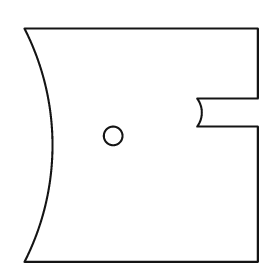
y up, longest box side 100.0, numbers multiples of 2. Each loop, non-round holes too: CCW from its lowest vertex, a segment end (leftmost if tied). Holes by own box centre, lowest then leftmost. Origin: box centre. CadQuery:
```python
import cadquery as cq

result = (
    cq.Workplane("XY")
    .moveTo(-50.0, -50.0)
    .lineTo(50.0, -50.0)
    .lineTo(50.0, 8.0)
    .lineTo(24.0, 8.0)
    .threePointArc((26.0, 14.0), (24.0, 20.0))
    .lineTo(50.0, 20.0)
    .lineTo(50.0, 50.0)
    .lineTo(-50.0, 50.0)
    .threePointArc((-38.0, 0.0), (-50.0, -50.0))
    .close()
    .moveTo(-12.0, 4.0)
    .circle(4.0)
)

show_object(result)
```